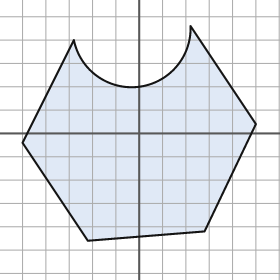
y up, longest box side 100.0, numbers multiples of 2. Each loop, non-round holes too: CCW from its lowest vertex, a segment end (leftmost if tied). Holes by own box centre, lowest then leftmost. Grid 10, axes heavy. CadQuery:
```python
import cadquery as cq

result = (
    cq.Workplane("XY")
    .moveTo(-22.0, -46.0)
    .lineTo(28.0, -42.0)
    .lineTo(50.0, 4.0)
    .lineTo(22.0, 46.0)
    .threePointArc((0.0, 20.0), (-28.0, 40.0))
    .lineTo(-50.0, -4.0)
    .close()
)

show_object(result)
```